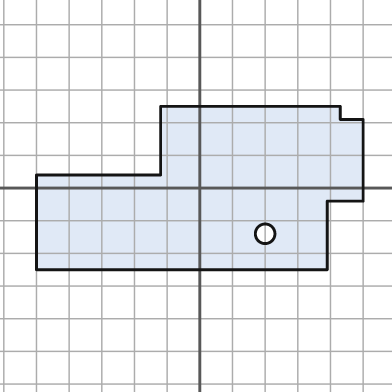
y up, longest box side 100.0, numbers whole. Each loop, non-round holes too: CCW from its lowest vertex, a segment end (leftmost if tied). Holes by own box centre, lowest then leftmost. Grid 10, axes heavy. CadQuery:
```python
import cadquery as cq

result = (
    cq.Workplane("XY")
    .moveTo(-50.0, -25.0)
    .lineTo(39.0, -25.0)
    .lineTo(39.0, -4.0)
    .lineTo(50.0, -4.0)
    .lineTo(50.0, 21.0)
    .lineTo(43.0, 21.0)
    .lineTo(43.0, 25.0)
    .lineTo(-12.0, 25.0)
    .lineTo(-12.0, 4.0)
    .lineTo(-50.0, 4.0)
    .close()
    .moveTo(20.0, -14.0)
    .circle(3.0)
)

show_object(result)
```